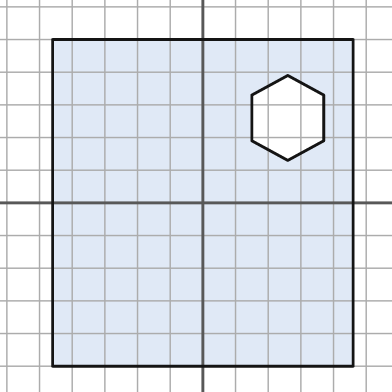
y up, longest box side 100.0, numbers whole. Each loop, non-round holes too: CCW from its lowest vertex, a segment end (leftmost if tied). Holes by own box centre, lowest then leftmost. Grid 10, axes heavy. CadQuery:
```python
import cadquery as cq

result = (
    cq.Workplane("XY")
    .moveTo(-46.0, -50.0)
    .lineTo(46.0, -50.0)
    .lineTo(46.0, 50.0)
    .lineTo(-46.0, 50.0)
    .close()
    .moveTo(26.0, 13.0)
    .lineTo(37.0, 19.0)
    .lineTo(37.0, 33.0)
    .lineTo(26.0, 39.0)
    .lineTo(15.0, 33.0)
    .lineTo(15.0, 19.0)
    .close()
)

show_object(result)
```